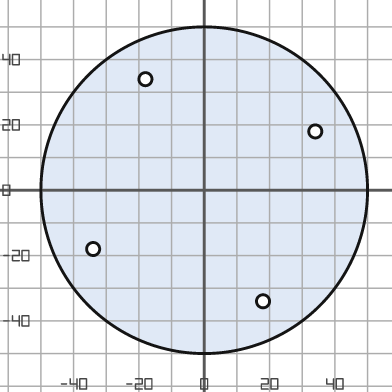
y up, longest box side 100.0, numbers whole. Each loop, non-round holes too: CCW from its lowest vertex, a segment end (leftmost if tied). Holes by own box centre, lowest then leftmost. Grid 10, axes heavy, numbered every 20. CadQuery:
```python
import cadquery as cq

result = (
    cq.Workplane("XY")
    .moveTo(0.0, 0.0)
    .circle(50.0)
    .moveTo(18.0, -34.0)
    .circle(2.0)
    .moveTo(-34.0, -18.0)
    .circle(2.0)
    .moveTo(34.0, 18.0)
    .circle(2.0)
    .moveTo(-18.0, 34.0)
    .circle(2.0)
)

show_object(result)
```